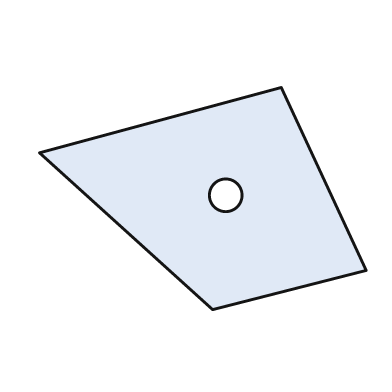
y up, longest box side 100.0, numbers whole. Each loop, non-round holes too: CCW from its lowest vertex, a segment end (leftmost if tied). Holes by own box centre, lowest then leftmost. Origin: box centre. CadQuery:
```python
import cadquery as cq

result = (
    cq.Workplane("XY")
    .moveTo(3.0, -34.0)
    .lineTo(50.0, -22.0)
    .lineTo(24.0, 34.0)
    .lineTo(-50.0, 14.0)
    .close()
    .moveTo(7.0, 1.0)
    .circle(5.0)
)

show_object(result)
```